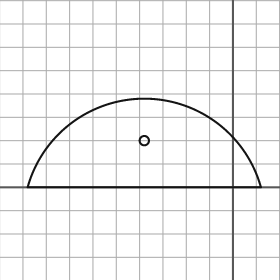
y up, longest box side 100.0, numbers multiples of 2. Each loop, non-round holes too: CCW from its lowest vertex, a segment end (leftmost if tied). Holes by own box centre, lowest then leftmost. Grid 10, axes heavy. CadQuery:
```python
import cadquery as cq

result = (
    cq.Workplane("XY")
    .moveTo(-88.0, 0.0)
    .lineTo(12.0, 0.0)
    .threePointArc((-38.0, 38.0), (-88.0, 0.0))
    .close()
    .moveTo(-38.0, 20.0)
    .circle(2.0)
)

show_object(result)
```